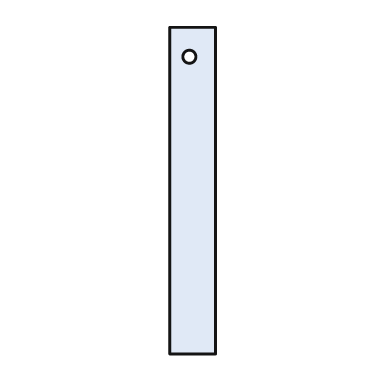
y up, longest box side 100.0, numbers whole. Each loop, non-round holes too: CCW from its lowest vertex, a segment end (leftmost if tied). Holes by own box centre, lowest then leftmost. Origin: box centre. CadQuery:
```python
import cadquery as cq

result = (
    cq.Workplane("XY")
    .moveTo(-7.0, -50.0)
    .lineTo(7.0, -50.0)
    .lineTo(7.0, 50.0)
    .lineTo(-7.0, 50.0)
    .close()
    .moveTo(-1.0, 41.0)
    .circle(2.0)
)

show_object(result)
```